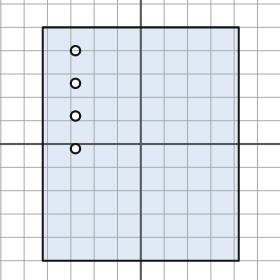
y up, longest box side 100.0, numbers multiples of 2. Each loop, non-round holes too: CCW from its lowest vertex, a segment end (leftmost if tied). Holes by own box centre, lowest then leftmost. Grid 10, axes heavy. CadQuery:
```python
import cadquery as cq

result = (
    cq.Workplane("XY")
    .moveTo(-42.0, -50.0)
    .lineTo(42.0, -50.0)
    .lineTo(42.0, 50.0)
    .lineTo(-42.0, 50.0)
    .close()
    .moveTo(-28.0, -2.0)
    .circle(2.0)
    .moveTo(-28.0, 12.0)
    .circle(2.0)
    .moveTo(-28.0, 26.0)
    .circle(2.0)
    .moveTo(-28.0, 40.0)
    .circle(2.0)
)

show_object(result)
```